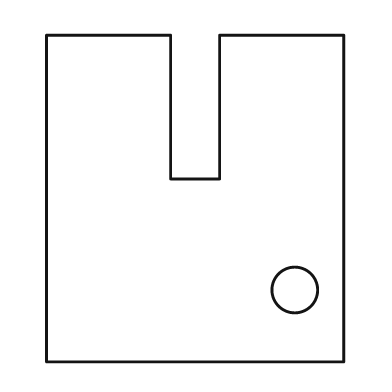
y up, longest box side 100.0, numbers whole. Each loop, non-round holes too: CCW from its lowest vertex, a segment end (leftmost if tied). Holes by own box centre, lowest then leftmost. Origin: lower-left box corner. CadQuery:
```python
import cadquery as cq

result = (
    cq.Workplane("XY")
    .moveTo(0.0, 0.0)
    .lineTo(91.0, 0.0)
    .lineTo(91.0, 100.0)
    .lineTo(53.0, 100.0)
    .lineTo(53.0, 56.0)
    .lineTo(38.0, 56.0)
    .lineTo(38.0, 100.0)
    .lineTo(0.0, 100.0)
    .close()
    .moveTo(76.0, 22.0)
    .circle(7.0)
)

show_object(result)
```